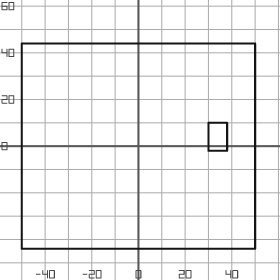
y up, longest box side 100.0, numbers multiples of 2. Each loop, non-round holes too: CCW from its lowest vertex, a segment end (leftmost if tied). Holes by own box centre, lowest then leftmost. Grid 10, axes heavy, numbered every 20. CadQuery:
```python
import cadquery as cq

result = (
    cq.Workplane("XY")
    .moveTo(-50.0, -44.0)
    .lineTo(50.0, -44.0)
    .lineTo(50.0, 44.0)
    .lineTo(-50.0, 44.0)
    .close()
    .moveTo(30.0, -2.0)
    .lineTo(38.0, -2.0)
    .lineTo(38.0, 10.0)
    .lineTo(30.0, 10.0)
    .close()
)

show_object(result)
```